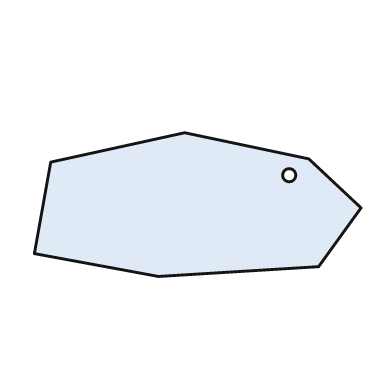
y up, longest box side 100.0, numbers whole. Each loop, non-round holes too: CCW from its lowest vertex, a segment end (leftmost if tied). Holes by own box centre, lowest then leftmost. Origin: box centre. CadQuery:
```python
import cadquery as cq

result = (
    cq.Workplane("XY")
    .moveTo(-12.0, -22.0)
    .lineTo(37.0, -19.0)
    .lineTo(50.0, -1.0)
    .lineTo(34.0, 14.0)
    .lineTo(-4.0, 22.0)
    .lineTo(-45.0, 13.0)
    .lineTo(-50.0, -15.0)
    .close()
    .moveTo(28.0, 9.0)
    .circle(2.0)
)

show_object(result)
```